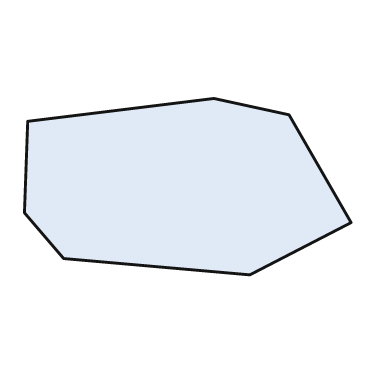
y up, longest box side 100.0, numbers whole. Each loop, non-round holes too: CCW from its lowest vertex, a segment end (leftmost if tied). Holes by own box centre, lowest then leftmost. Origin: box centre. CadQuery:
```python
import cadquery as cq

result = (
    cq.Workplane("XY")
    .moveTo(19.0, -27.0)
    .lineTo(50.0, -11.0)
    .lineTo(31.0, 22.0)
    .lineTo(8.0, 27.0)
    .lineTo(-49.0, 20.0)
    .lineTo(-50.0, -8.0)
    .lineTo(-38.0, -22.0)
    .close()
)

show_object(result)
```